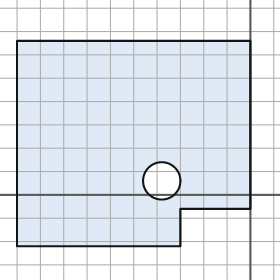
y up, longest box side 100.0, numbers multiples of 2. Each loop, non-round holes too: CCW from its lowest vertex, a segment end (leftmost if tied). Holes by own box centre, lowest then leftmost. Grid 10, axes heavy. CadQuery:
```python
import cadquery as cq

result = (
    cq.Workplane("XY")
    .moveTo(-100.0, -22.0)
    .lineTo(-30.0, -22.0)
    .lineTo(-30.0, -6.0)
    .lineTo(0.0, -6.0)
    .lineTo(0.0, 66.0)
    .lineTo(-100.0, 66.0)
    .close()
    .moveTo(-38.0, 6.0)
    .circle(8.0)
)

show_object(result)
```